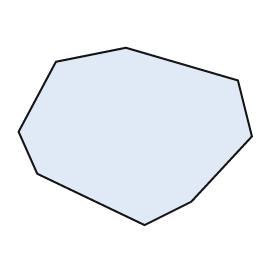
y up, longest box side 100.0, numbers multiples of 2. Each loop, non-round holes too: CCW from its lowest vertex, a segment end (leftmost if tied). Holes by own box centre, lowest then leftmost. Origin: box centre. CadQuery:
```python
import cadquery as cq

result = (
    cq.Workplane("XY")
    .moveTo(4.0, -38.0)
    .lineTo(24.0, -28.0)
    .lineTo(50.0, 0.0)
    .lineTo(44.0, 24.0)
    .lineTo(-4.0, 38.0)
    .lineTo(-34.0, 32.0)
    .lineTo(-50.0, 2.0)
    .lineTo(-42.0, -16.0)
    .close()
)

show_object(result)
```